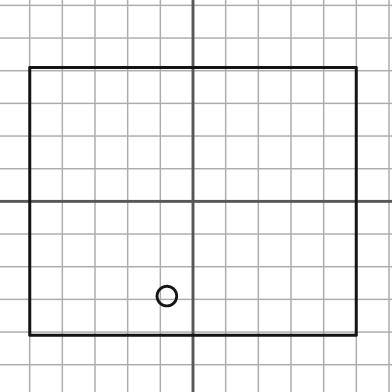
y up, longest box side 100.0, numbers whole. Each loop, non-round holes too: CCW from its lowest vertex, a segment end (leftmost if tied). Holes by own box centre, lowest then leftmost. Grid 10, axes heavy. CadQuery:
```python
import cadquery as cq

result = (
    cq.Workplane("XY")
    .moveTo(-50.0, -41.0)
    .lineTo(50.0, -41.0)
    .lineTo(50.0, 41.0)
    .lineTo(-50.0, 41.0)
    .close()
    .moveTo(-8.0, -29.0)
    .circle(3.0)
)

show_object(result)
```